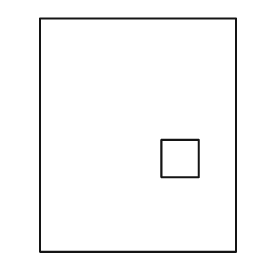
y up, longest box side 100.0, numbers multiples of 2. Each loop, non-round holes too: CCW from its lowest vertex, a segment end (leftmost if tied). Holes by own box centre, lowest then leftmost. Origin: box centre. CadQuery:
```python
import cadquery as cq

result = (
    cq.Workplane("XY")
    .moveTo(-42.0, -50.0)
    .lineTo(42.0, -50.0)
    .lineTo(42.0, 50.0)
    .lineTo(-42.0, 50.0)
    .close()
    .moveTo(10.0, -18.0)
    .lineTo(26.0, -18.0)
    .lineTo(26.0, -2.0)
    .lineTo(10.0, -2.0)
    .close()
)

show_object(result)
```